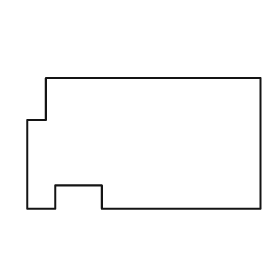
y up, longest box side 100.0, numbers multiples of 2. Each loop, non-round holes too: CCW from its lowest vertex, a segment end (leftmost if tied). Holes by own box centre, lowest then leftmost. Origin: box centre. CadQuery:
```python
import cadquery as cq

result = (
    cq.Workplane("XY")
    .moveTo(-50.0, -28.0)
    .lineTo(-38.0, -28.0)
    .lineTo(-38.0, -18.0)
    .lineTo(-18.0, -18.0)
    .lineTo(-18.0, -28.0)
    .lineTo(50.0, -28.0)
    .lineTo(50.0, 28.0)
    .lineTo(-42.0, 28.0)
    .lineTo(-42.0, 10.0)
    .lineTo(-50.0, 10.0)
    .close()
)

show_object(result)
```